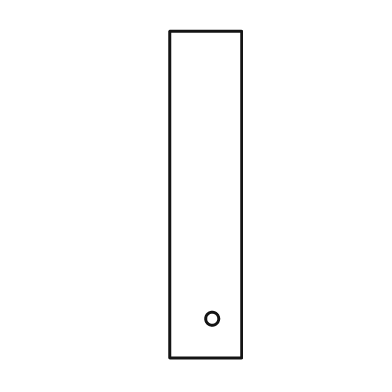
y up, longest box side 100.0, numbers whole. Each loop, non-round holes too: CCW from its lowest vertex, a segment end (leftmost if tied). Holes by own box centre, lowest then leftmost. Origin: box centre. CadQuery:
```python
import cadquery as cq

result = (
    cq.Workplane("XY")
    .moveTo(-11.0, -50.0)
    .lineTo(11.0, -50.0)
    .lineTo(11.0, 50.0)
    .lineTo(-11.0, 50.0)
    .close()
    .moveTo(2.0, -38.0)
    .circle(2.0)
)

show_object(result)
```